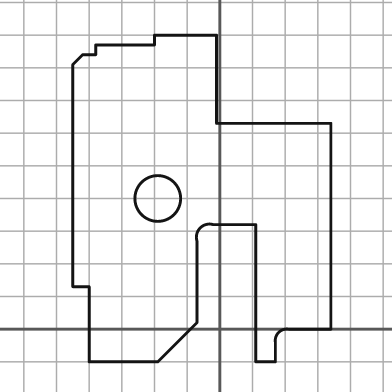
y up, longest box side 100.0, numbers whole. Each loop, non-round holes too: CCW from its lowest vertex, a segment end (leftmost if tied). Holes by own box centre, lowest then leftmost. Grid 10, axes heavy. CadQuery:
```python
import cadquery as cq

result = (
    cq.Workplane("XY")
    .moveTo(-40.0, -10.0)
    .lineTo(-19.0, -10.0)
    .lineTo(-7.0, 2.0)
    .lineTo(-7.0, 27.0)
    .threePointArc((-6.0, 31.0), (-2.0, 32.0))
    .lineTo(11.0, 32.0)
    .lineTo(11.0, -10.0)
    .lineTo(17.0, -10.0)
    .lineTo(17.0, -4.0)
    .threePointArc((18.0, -1.0), (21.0, 0.0))
    .lineTo(34.0, 0.0)
    .lineTo(34.0, 63.0)
    .lineTo(-1.0, 63.0)
    .lineTo(-1.0, 90.0)
    .lineTo(-20.0, 90.0)
    .lineTo(-20.0, 87.0)
    .lineTo(-38.0, 87.0)
    .lineTo(-38.0, 84.0)
    .lineTo(-42.0, 84.0)
    .lineTo(-45.0, 81.0)
    .lineTo(-45.0, 13.0)
    .lineTo(-40.0, 13.0)
    .close()
    .moveTo(-19.0, 40.0)
    .circle(7.0)
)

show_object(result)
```